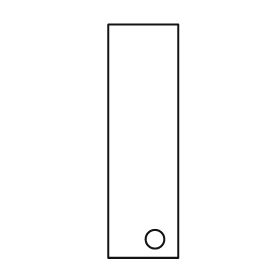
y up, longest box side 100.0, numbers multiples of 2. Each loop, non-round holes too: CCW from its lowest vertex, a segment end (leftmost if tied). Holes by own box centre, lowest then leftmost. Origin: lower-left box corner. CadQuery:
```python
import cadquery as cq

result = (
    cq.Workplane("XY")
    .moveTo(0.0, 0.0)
    .lineTo(30.0, 0.0)
    .lineTo(30.0, 100.0)
    .lineTo(0.0, 100.0)
    .close()
    .moveTo(20.0, 8.0)
    .circle(4.0)
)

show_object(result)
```